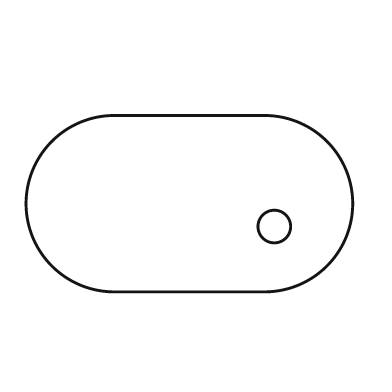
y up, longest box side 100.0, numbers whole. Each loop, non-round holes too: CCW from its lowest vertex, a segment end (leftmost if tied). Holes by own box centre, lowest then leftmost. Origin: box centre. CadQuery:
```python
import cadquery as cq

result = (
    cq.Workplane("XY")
    .moveTo(-23.0, -27.0)
    .lineTo(23.0, -27.0)
    .threePointArc((50.0, 0.0), (23.0, 27.0))
    .lineTo(-23.0, 27.0)
    .threePointArc((-50.0, 0.0), (-23.0, -27.0))
    .close()
    .moveTo(26.0, -7.0)
    .circle(5.0)
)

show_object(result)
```